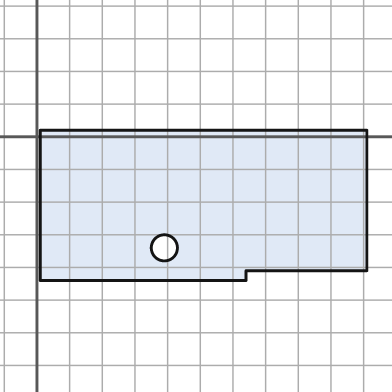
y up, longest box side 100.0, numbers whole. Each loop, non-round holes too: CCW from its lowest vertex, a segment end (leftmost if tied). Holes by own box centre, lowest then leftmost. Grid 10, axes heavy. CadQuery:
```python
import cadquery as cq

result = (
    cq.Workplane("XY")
    .moveTo(1.0, -44.0)
    .lineTo(64.0, -44.0)
    .lineTo(64.0, -41.0)
    .lineTo(101.0, -41.0)
    .lineTo(101.0, 2.0)
    .lineTo(1.0, 2.0)
    .close()
    .moveTo(39.0, -34.0)
    .circle(4.0)
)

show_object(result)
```